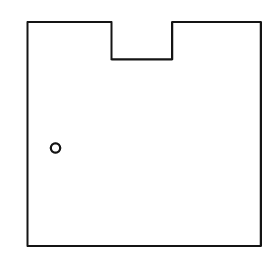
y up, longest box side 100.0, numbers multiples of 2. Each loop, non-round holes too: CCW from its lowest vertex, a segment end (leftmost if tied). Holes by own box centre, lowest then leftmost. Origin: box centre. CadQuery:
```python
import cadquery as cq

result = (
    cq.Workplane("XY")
    .moveTo(-50.0, -48.0)
    .lineTo(50.0, -48.0)
    .lineTo(50.0, 48.0)
    .lineTo(12.0, 48.0)
    .lineTo(12.0, 32.0)
    .lineTo(-14.0, 32.0)
    .lineTo(-14.0, 48.0)
    .lineTo(-50.0, 48.0)
    .close()
    .moveTo(-38.0, -6.0)
    .circle(2.0)
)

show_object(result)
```